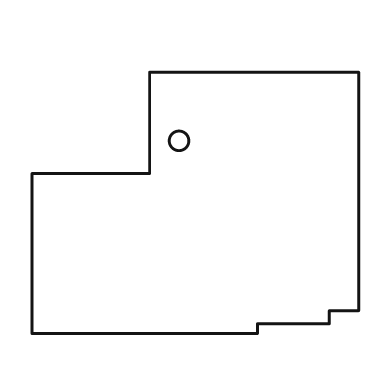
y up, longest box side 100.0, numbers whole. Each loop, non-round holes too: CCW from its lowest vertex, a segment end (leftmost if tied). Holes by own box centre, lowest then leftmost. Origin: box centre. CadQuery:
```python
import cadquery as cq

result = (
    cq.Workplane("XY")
    .moveTo(-50.0, -40.0)
    .lineTo(19.0, -40.0)
    .lineTo(19.0, -37.0)
    .lineTo(41.0, -37.0)
    .lineTo(41.0, -33.0)
    .lineTo(50.0, -33.0)
    .lineTo(50.0, 40.0)
    .lineTo(-14.0, 40.0)
    .lineTo(-14.0, 9.0)
    .lineTo(-50.0, 9.0)
    .close()
    .moveTo(-5.0, 19.0)
    .circle(3.0)
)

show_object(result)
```